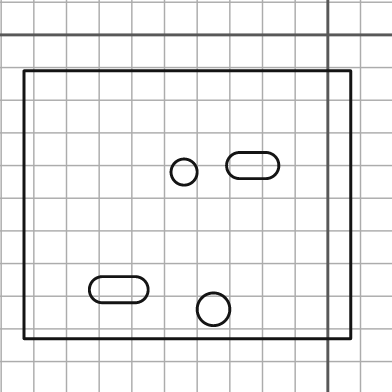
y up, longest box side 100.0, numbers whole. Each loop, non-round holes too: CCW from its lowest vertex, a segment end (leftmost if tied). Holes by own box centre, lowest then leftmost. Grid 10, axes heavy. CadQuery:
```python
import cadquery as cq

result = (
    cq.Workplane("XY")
    .moveTo(-93.0, -93.0)
    .lineTo(7.0, -93.0)
    .lineTo(7.0, -11.0)
    .lineTo(-93.0, -11.0)
    .close()
    .moveTo(-35.0, -84.0)
    .circle(5.0)
    .moveTo(-69.0, -82.0)
    .lineTo(-59.0, -82.0)
    .threePointArc((-55.0, -78.0), (-59.0, -74.0))
    .lineTo(-69.0, -74.0)
    .threePointArc((-73.0, -78.0), (-69.0, -82.0))
    .close()
    .moveTo(-44.0, -42.0)
    .circle(4.0)
    .moveTo(-27.0, -44.0)
    .lineTo(-19.0, -44.0)
    .threePointArc((-15.0, -40.0), (-19.0, -36.0))
    .lineTo(-27.0, -36.0)
    .threePointArc((-31.0, -40.0), (-27.0, -44.0))
    .close()
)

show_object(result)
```